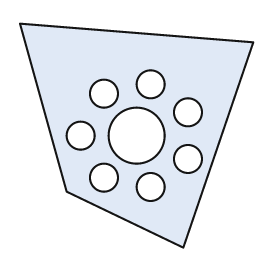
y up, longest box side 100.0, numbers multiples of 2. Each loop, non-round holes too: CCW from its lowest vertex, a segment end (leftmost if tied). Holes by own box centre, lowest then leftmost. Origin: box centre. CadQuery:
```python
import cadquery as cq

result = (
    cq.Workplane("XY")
    .moveTo(20.0, -48.0)
    .lineTo(50.0, 40.0)
    .lineTo(-50.0, 48.0)
    .lineTo(-30.0, -24.0)
    .close()
    .moveTo(6.0, -22.0)
    .circle(6.0)
    .moveTo(-14.0, -18.0)
    .circle(6.0)
    .moveTo(22.0, -10.0)
    .circle(6.0)
    .moveTo(-24.0, 0.0)
    .circle(6.0)
    .moveTo(0.0, 0.0)
    .circle(12.0)
    .moveTo(22.0, 10.0)
    .circle(6.0)
    .moveTo(-14.0, 18.0)
    .circle(6.0)
    .moveTo(6.0, 22.0)
    .circle(6.0)
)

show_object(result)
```